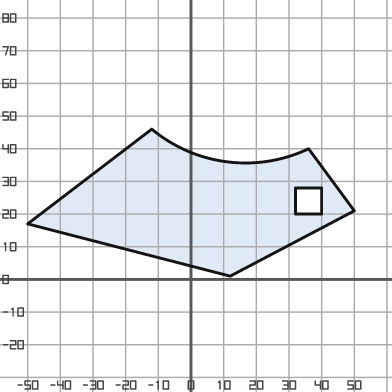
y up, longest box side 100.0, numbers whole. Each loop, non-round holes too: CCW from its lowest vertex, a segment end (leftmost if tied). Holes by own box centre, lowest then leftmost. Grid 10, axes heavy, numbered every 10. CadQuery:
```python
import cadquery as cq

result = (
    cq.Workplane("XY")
    .moveTo(12.0, 1.0)
    .lineTo(50.0, 21.0)
    .lineTo(36.0, 40.0)
    .threePointArc((11.0, 36.0), (-12.0, 46.0))
    .lineTo(-50.0, 17.0)
    .close()
    .moveTo(32.0, 20.0)
    .lineTo(40.0, 20.0)
    .lineTo(40.0, 28.0)
    .lineTo(32.0, 28.0)
    .close()
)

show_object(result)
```